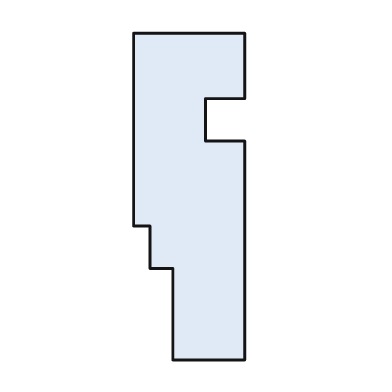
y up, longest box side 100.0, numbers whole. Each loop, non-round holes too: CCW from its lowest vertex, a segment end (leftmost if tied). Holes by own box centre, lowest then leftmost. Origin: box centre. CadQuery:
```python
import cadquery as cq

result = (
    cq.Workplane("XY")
    .moveTo(-5.0, -50.0)
    .lineTo(17.0, -50.0)
    .lineTo(17.0, 17.0)
    .lineTo(5.0, 17.0)
    .lineTo(5.0, 30.0)
    .lineTo(17.0, 30.0)
    .lineTo(17.0, 50.0)
    .lineTo(-17.0, 50.0)
    .lineTo(-17.0, -9.0)
    .lineTo(-12.0, -9.0)
    .lineTo(-12.0, -22.0)
    .lineTo(-5.0, -22.0)
    .close()
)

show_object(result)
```